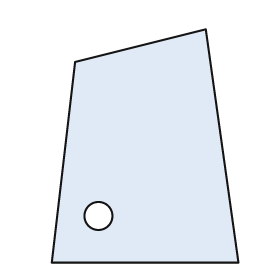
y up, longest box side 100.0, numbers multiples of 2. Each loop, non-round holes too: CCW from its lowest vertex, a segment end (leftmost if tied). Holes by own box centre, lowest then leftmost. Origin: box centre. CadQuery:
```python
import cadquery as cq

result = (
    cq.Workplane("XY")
    .moveTo(-40.0, -50.0)
    .lineTo(40.0, -50.0)
    .lineTo(26.0, 50.0)
    .lineTo(-30.0, 36.0)
    .close()
    .moveTo(-20.0, -30.0)
    .circle(6.0)
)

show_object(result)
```